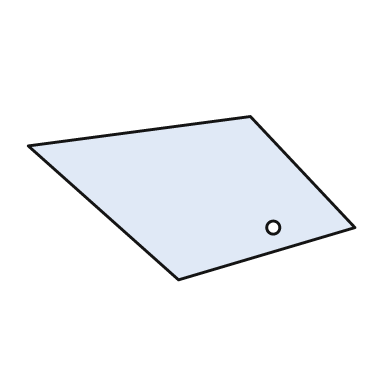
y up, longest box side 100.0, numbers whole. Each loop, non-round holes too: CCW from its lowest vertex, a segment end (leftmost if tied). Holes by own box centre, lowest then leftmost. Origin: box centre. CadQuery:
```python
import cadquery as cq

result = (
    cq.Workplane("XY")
    .moveTo(-4.0, -25.0)
    .lineTo(50.0, -9.0)
    .lineTo(18.0, 25.0)
    .lineTo(-50.0, 16.0)
    .close()
    .moveTo(25.0, -9.0)
    .circle(2.0)
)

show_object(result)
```